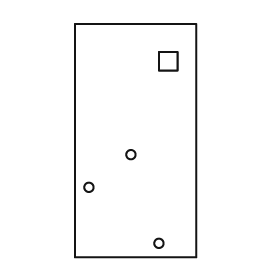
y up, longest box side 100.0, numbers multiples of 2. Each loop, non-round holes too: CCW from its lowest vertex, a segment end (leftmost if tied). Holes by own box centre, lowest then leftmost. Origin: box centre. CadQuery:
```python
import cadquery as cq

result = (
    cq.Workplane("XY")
    .moveTo(-26.0, -50.0)
    .lineTo(26.0, -50.0)
    .lineTo(26.0, 50.0)
    .lineTo(-26.0, 50.0)
    .close()
    .moveTo(10.0, -44.0)
    .circle(2.0)
    .moveTo(-20.0, -20.0)
    .circle(2.0)
    .moveTo(-2.0, -6.0)
    .circle(2.0)
    .moveTo(10.0, 30.0)
    .lineTo(18.0, 30.0)
    .lineTo(18.0, 38.0)
    .lineTo(10.0, 38.0)
    .close()
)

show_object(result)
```